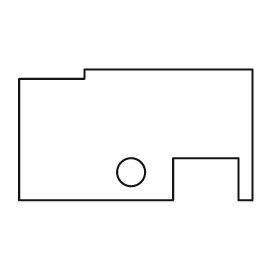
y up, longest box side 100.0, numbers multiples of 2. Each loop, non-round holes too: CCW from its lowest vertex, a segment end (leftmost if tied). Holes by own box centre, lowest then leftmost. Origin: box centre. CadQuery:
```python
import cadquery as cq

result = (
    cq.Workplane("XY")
    .moveTo(-50.0, -28.0)
    .lineTo(16.0, -28.0)
    .lineTo(16.0, -10.0)
    .lineTo(44.0, -10.0)
    .lineTo(44.0, -28.0)
    .lineTo(50.0, -28.0)
    .lineTo(50.0, 28.0)
    .lineTo(-22.0, 28.0)
    .lineTo(-22.0, 24.0)
    .lineTo(-50.0, 24.0)
    .close()
    .moveTo(-2.0, -16.0)
    .circle(6.0)
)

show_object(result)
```